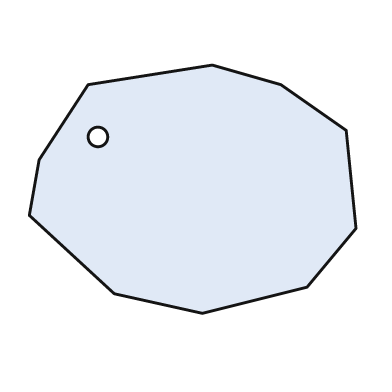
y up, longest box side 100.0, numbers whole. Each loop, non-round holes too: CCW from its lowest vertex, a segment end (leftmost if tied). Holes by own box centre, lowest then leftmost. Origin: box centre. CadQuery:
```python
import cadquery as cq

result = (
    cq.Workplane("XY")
    .moveTo(3.0, -38.0)
    .lineTo(35.0, -30.0)
    .lineTo(50.0, -12.0)
    .lineTo(47.0, 18.0)
    .lineTo(27.0, 32.0)
    .lineTo(6.0, 38.0)
    .lineTo(-32.0, 32.0)
    .lineTo(-47.0, 9.0)
    .lineTo(-50.0, -8.0)
    .lineTo(-24.0, -32.0)
    .close()
    .moveTo(-29.0, 16.0)
    .circle(3.0)
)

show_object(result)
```